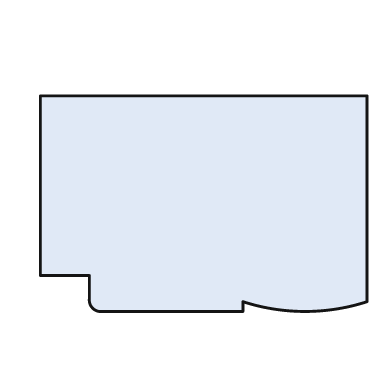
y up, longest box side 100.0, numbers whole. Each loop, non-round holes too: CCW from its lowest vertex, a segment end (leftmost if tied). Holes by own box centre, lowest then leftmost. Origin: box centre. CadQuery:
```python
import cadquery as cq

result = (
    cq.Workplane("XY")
    .moveTo(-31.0, -33.0)
    .lineTo(12.0, -33.0)
    .lineTo(12.0, -30.0)
    .threePointArc((31.0, -33.0), (50.0, -30.0))
    .lineTo(50.0, 33.0)
    .lineTo(-50.0, 33.0)
    .lineTo(-50.0, -22.0)
    .lineTo(-35.0, -22.0)
    .lineTo(-35.0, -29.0)
    .threePointArc((-34.0, -32.0), (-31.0, -33.0))
    .close()
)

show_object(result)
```